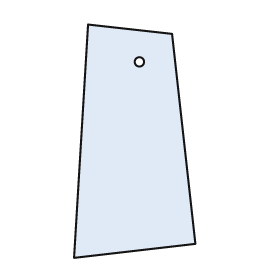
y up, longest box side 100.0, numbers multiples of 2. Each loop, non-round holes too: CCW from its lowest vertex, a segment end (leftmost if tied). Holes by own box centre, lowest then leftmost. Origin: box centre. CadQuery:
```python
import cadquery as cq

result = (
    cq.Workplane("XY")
    .moveTo(-26.0, -50.0)
    .lineTo(26.0, -44.0)
    .lineTo(16.0, 46.0)
    .lineTo(-20.0, 50.0)
    .close()
    .moveTo(2.0, 34.0)
    .circle(2.0)
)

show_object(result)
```